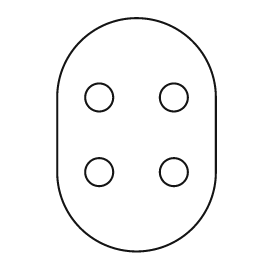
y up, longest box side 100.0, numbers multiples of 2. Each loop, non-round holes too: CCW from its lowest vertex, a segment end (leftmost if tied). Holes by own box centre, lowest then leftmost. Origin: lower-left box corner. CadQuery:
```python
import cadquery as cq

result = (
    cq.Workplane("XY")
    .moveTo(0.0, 34.0)
    .threePointArc((34.0, 0.0), (68.0, 34.0))
    .lineTo(68.0, 66.0)
    .threePointArc((34.0, 100.0), (0.0, 66.0))
    .close()
    .moveTo(18.0, 34.0)
    .circle(6.0)
    .moveTo(50.0, 34.0)
    .circle(6.0)
    .moveTo(18.0, 66.0)
    .circle(6.0)
    .moveTo(50.0, 66.0)
    .circle(6.0)
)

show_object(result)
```